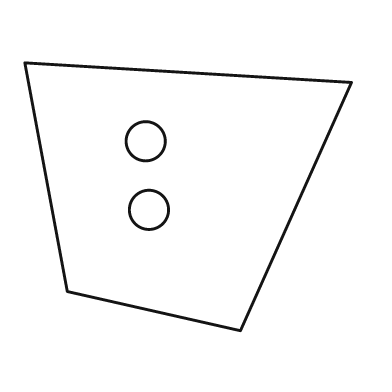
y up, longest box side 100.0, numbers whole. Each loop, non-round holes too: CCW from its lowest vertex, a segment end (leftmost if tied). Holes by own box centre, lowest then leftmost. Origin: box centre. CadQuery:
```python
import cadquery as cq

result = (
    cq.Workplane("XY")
    .moveTo(16.0, -41.0)
    .lineTo(50.0, 35.0)
    .lineTo(-50.0, 41.0)
    .lineTo(-37.0, -29.0)
    .close()
    .moveTo(-12.0, -4.0)
    .circle(6.0)
    .moveTo(-13.0, 17.0)
    .circle(6.0)
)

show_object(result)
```